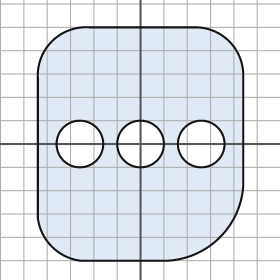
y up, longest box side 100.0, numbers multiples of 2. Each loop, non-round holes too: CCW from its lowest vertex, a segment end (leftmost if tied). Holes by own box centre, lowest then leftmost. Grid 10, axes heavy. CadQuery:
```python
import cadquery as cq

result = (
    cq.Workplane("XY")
    .moveTo(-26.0, -50.0)
    .lineTo(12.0, -50.0)
    .threePointArc((34.0, -40.0), (44.0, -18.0))
    .lineTo(44.0, 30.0)
    .threePointArc((38.0, 44.0), (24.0, 50.0))
    .lineTo(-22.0, 50.0)
    .threePointArc((-38.0, 44.0), (-44.0, 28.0))
    .lineTo(-44.0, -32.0)
    .threePointArc((-38.0, -44.0), (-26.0, -50.0))
    .close()
    .moveTo(-26.0, 0.0)
    .circle(10.0)
    .moveTo(0.0, 0.0)
    .circle(10.0)
    .moveTo(26.0, 0.0)
    .circle(10.0)
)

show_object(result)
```